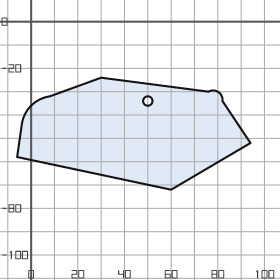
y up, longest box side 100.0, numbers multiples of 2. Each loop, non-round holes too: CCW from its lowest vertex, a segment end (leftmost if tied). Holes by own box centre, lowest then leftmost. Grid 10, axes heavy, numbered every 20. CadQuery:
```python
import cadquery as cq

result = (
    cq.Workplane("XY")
    .moveTo(60.0, -72.0)
    .lineTo(94.0, -52.0)
    .lineTo(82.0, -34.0)
    .threePointArc((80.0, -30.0), (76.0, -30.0))
    .lineTo(30.0, -24.0)
    .lineTo(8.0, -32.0)
    .threePointArc((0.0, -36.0), (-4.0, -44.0))
    .lineTo(-6.0, -58.0)
    .close()
    .moveTo(50.0, -34.0)
    .circle(2.0)
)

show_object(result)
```